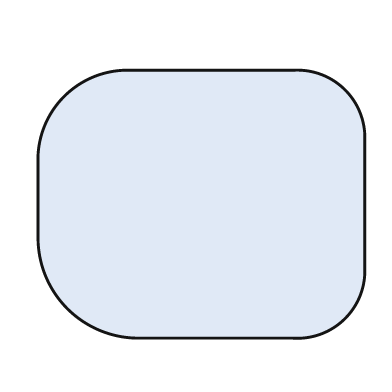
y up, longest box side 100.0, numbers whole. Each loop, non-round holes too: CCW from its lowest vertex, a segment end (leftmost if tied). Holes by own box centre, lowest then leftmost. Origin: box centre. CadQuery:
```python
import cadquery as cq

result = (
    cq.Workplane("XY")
    .moveTo(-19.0, -41.0)
    .lineTo(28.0, -41.0)
    .threePointArc((44.0, -35.0), (50.0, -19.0))
    .lineTo(50.0, 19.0)
    .threePointArc((44.0, 35.0), (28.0, 41.0))
    .lineTo(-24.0, 41.0)
    .threePointArc((-42.0, 33.0), (-50.0, 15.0))
    .lineTo(-50.0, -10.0)
    .threePointArc((-41.0, -32.0), (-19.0, -41.0))
    .close()
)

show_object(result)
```